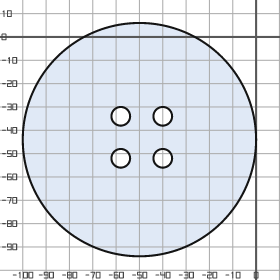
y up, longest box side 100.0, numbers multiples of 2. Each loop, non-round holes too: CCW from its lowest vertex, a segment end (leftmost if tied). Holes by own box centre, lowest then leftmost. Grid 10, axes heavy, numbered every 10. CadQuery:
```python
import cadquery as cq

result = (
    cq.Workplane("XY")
    .moveTo(-50.0, -44.0)
    .circle(50.0)
    .moveTo(-58.0, -52.0)
    .circle(4.0)
    .moveTo(-40.0, -52.0)
    .circle(4.0)
    .moveTo(-58.0, -34.0)
    .circle(4.0)
    .moveTo(-40.0, -34.0)
    .circle(4.0)
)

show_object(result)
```